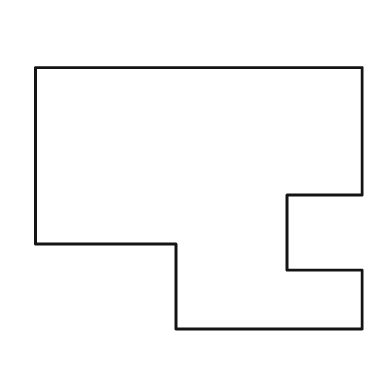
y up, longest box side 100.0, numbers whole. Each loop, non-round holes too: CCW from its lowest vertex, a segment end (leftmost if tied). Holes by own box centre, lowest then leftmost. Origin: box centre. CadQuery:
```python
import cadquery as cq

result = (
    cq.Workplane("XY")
    .moveTo(-7.0, -40.0)
    .lineTo(50.0, -40.0)
    .lineTo(50.0, -22.0)
    .lineTo(27.0, -22.0)
    .lineTo(27.0, 1.0)
    .lineTo(50.0, 1.0)
    .lineTo(50.0, 40.0)
    .lineTo(-50.0, 40.0)
    .lineTo(-50.0, -14.0)
    .lineTo(-7.0, -14.0)
    .close()
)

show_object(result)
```